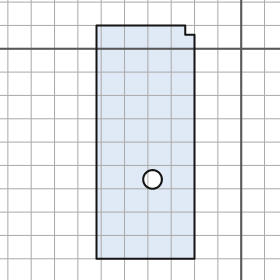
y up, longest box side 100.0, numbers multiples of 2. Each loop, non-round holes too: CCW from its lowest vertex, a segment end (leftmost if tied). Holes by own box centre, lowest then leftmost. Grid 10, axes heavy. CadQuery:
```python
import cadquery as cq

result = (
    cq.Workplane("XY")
    .moveTo(-62.0, -90.0)
    .lineTo(-20.0, -90.0)
    .lineTo(-20.0, 6.0)
    .lineTo(-24.0, 6.0)
    .lineTo(-24.0, 10.0)
    .lineTo(-62.0, 10.0)
    .close()
    .moveTo(-38.0, -56.0)
    .circle(4.0)
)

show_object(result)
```